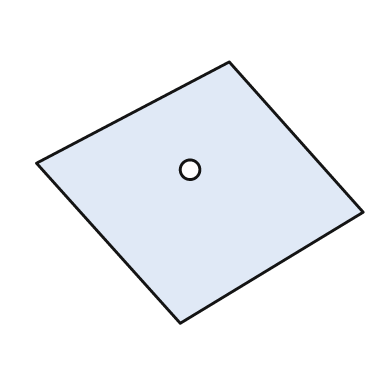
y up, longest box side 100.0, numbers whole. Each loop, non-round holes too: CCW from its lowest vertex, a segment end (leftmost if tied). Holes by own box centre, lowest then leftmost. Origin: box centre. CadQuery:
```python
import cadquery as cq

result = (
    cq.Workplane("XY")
    .moveTo(-6.0, -40.0)
    .lineTo(50.0, -6.0)
    .lineTo(9.0, 40.0)
    .lineTo(-50.0, 9.0)
    .close()
    .moveTo(-3.0, 7.0)
    .circle(3.0)
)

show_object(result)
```